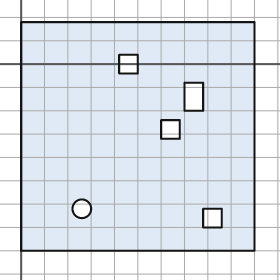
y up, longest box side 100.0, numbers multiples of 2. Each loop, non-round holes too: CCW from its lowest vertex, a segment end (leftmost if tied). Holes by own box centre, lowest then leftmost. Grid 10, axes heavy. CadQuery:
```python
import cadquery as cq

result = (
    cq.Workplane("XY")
    .moveTo(0.0, -80.0)
    .lineTo(100.0, -80.0)
    .lineTo(100.0, 18.0)
    .lineTo(0.0, 18.0)
    .close()
    .moveTo(78.0, -70.0)
    .lineTo(86.0, -70.0)
    .lineTo(86.0, -62.0)
    .lineTo(78.0, -62.0)
    .close()
    .moveTo(26.0, -62.0)
    .circle(4.0)
    .moveTo(60.0, -32.0)
    .lineTo(68.0, -32.0)
    .lineTo(68.0, -24.0)
    .lineTo(60.0, -24.0)
    .close()
    .moveTo(70.0, -20.0)
    .lineTo(78.0, -20.0)
    .lineTo(78.0, -8.0)
    .lineTo(70.0, -8.0)
    .close()
    .moveTo(42.0, -4.0)
    .lineTo(50.0, -4.0)
    .lineTo(50.0, 4.0)
    .lineTo(42.0, 4.0)
    .close()
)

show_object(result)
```